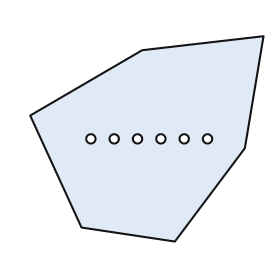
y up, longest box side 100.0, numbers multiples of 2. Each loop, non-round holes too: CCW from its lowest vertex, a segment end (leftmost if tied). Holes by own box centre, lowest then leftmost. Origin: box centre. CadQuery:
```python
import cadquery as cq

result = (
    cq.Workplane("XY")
    .moveTo(12.0, -44.0)
    .lineTo(42.0, -4.0)
    .lineTo(50.0, 44.0)
    .lineTo(-2.0, 38.0)
    .lineTo(-50.0, 10.0)
    .lineTo(-28.0, -38.0)
    .close()
    .moveTo(-24.0, 0.0)
    .circle(2.0)
    .moveTo(-14.0, 0.0)
    .circle(2.0)
    .moveTo(-4.0, 0.0)
    .circle(2.0)
    .moveTo(6.0, 0.0)
    .circle(2.0)
    .moveTo(16.0, 0.0)
    .circle(2.0)
    .moveTo(26.0, 0.0)
    .circle(2.0)
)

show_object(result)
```